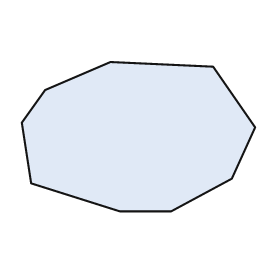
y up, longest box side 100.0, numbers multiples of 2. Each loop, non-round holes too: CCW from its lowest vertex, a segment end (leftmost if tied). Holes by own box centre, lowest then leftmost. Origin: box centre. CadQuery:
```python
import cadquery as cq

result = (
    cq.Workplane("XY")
    .moveTo(-8.0, -32.0)
    .lineTo(14.0, -32.0)
    .lineTo(40.0, -18.0)
    .lineTo(50.0, 4.0)
    .lineTo(32.0, 30.0)
    .lineTo(-12.0, 32.0)
    .lineTo(-40.0, 20.0)
    .lineTo(-50.0, 6.0)
    .lineTo(-46.0, -20.0)
    .close()
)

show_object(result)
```